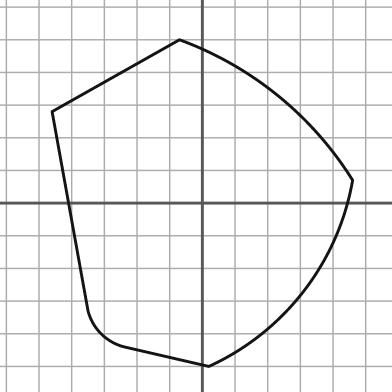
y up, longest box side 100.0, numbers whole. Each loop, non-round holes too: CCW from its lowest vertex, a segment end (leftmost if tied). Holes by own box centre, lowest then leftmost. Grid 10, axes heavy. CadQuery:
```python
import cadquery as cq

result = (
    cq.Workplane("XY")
    .moveTo(2.0, -50.0)
    .threePointArc((31.0, -27.0), (46.0, 7.0))
    .threePointArc((23.0, 33.0), (-7.0, 50.0))
    .lineTo(-46.0, 28.0)
    .lineTo(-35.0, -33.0)
    .threePointArc((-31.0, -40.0), (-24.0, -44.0))
    .close()
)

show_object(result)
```